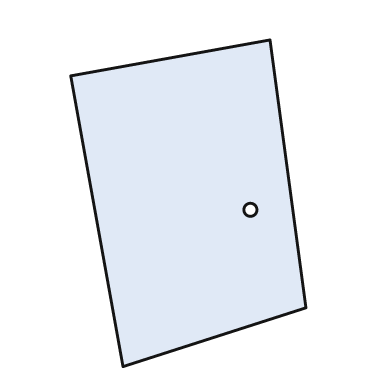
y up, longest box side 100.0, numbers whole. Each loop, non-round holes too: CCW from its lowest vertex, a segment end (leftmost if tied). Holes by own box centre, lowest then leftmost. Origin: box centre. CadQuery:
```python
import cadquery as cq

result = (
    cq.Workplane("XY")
    .moveTo(-20.0, -50.0)
    .lineTo(36.0, -32.0)
    .lineTo(25.0, 50.0)
    .lineTo(-36.0, 39.0)
    .close()
    .moveTo(19.0, -2.0)
    .circle(2.0)
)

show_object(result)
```